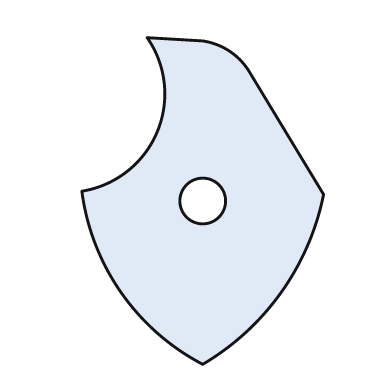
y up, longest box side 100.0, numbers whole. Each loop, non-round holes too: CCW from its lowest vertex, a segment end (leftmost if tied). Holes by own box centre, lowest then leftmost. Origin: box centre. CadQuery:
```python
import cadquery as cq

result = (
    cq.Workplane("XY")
    .moveTo(0.0, -50.0)
    .threePointArc((24.0, -28.0), (37.0, 2.0))
    .lineTo(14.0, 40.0)
    .threePointArc((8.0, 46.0), (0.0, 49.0))
    .lineTo(-17.0, 50.0)
    .threePointArc((-14.0, 21.0), (-37.0, 3.0))
    .threePointArc((-25.0, -28.0), (0.0, -50.0))
    .close()
    .moveTo(0.0, 0.0)
    .circle(7.0)
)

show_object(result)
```